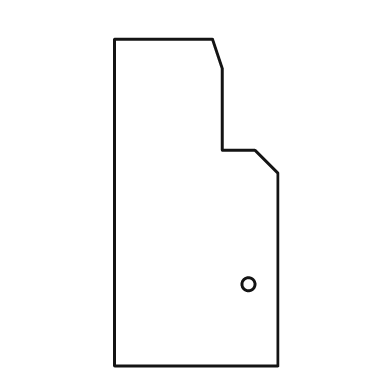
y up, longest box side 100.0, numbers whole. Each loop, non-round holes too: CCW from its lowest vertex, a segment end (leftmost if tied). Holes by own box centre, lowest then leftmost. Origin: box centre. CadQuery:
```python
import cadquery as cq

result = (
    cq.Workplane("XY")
    .moveTo(-25.0, -50.0)
    .lineTo(25.0, -50.0)
    .lineTo(25.0, 9.0)
    .lineTo(18.0, 16.0)
    .lineTo(8.0, 16.0)
    .lineTo(8.0, 41.0)
    .lineTo(5.0, 50.0)
    .lineTo(-25.0, 50.0)
    .close()
    .moveTo(16.0, -25.0)
    .circle(2.0)
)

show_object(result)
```